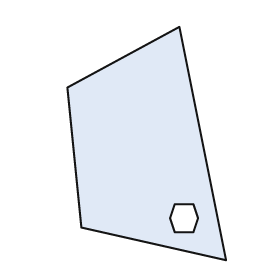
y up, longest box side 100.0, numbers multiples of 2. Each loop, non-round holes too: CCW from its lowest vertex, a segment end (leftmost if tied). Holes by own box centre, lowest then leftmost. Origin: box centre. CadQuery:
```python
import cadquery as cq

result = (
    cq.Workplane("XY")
    .moveTo(34.0, -50.0)
    .lineTo(14.0, 50.0)
    .lineTo(-34.0, 24.0)
    .lineTo(-28.0, -36.0)
    .close()
    .moveTo(12.0, -38.0)
    .lineTo(20.0, -38.0)
    .lineTo(22.0, -32.0)
    .lineTo(20.0, -26.0)
    .lineTo(12.0, -26.0)
    .lineTo(10.0, -32.0)
    .close()
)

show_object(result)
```